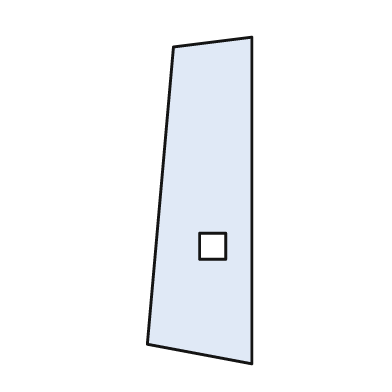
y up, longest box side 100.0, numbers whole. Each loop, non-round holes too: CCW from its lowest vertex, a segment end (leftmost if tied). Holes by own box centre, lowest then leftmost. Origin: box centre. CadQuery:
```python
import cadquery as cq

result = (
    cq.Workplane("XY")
    .moveTo(16.0, -50.0)
    .lineTo(16.0, 50.0)
    .lineTo(-8.0, 47.0)
    .lineTo(-16.0, -44.0)
    .close()
    .moveTo(0.0, -18.0)
    .lineTo(8.0, -18.0)
    .lineTo(8.0, -10.0)
    .lineTo(0.0, -10.0)
    .close()
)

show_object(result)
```